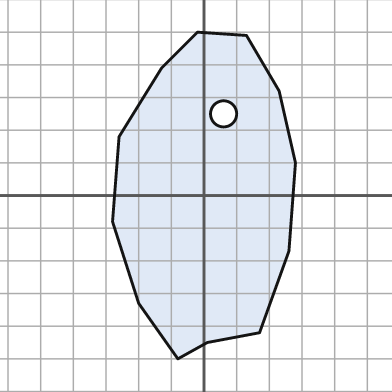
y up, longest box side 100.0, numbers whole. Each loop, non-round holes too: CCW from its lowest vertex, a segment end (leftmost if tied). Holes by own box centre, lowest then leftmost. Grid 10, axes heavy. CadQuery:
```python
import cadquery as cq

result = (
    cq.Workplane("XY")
    .moveTo(-8.0, -50.0)
    .lineTo(1.0, -45.0)
    .lineTo(17.0, -42.0)
    .lineTo(26.0, -17.0)
    .lineTo(28.0, 10.0)
    .lineTo(23.0, 32.0)
    .lineTo(13.0, 49.0)
    .lineTo(-2.0, 50.0)
    .lineTo(-13.0, 39.0)
    .lineTo(-26.0, 18.0)
    .lineTo(-28.0, -8.0)
    .lineTo(-20.0, -33.0)
    .close()
    .moveTo(6.0, 25.0)
    .circle(4.0)
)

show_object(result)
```